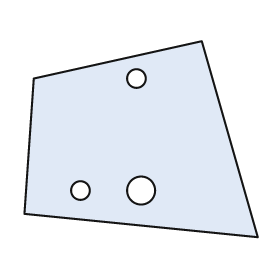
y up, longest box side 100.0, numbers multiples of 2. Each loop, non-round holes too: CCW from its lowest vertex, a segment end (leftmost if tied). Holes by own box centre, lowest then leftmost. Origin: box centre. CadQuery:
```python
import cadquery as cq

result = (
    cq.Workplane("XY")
    .moveTo(50.0, -42.0)
    .lineTo(26.0, 42.0)
    .lineTo(-46.0, 26.0)
    .lineTo(-50.0, -32.0)
    .close()
    .moveTo(-26.0, -22.0)
    .circle(4.0)
    .moveTo(0.0, -22.0)
    .circle(6.0)
    .moveTo(-2.0, 26.0)
    .circle(4.0)
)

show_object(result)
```